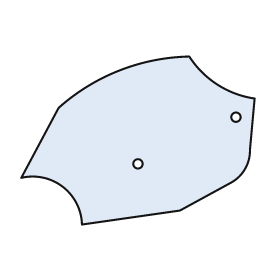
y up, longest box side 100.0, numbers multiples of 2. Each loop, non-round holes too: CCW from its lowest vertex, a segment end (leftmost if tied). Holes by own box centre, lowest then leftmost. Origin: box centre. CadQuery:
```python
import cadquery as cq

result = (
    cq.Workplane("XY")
    .moveTo(-24.0, -36.0)
    .lineTo(18.0, -30.0)
    .lineTo(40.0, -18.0)
    .threePointArc((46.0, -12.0), (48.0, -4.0))
    .lineTo(50.0, 18.0)
    .threePointArc((34.0, 24.0), (22.0, 36.0))
    .threePointArc((-8.0, 30.0), (-34.0, 14.0))
    .lineTo(-50.0, -16.0)
    .threePointArc((-32.0, -20.0), (-24.0, -36.0))
    .close()
    .moveTo(0.0, -10.0)
    .circle(2.0)
    .moveTo(42.0, 10.0)
    .circle(2.0)
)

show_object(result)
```